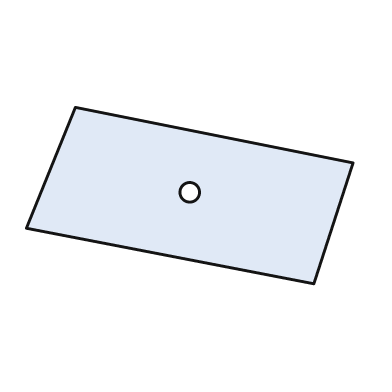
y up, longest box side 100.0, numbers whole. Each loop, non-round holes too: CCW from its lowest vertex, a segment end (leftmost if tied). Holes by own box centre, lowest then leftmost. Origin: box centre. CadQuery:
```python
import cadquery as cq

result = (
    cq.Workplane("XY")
    .moveTo(38.0, -27.0)
    .lineTo(50.0, 10.0)
    .lineTo(-35.0, 27.0)
    .lineTo(-50.0, -10.0)
    .close()
    .moveTo(0.0, 1.0)
    .circle(3.0)
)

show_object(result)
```